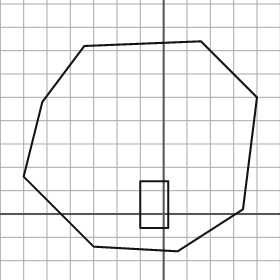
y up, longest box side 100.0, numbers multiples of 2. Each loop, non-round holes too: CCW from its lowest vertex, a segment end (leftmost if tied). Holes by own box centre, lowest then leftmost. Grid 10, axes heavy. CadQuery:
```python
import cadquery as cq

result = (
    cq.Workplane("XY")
    .moveTo(6.0, -16.0)
    .lineTo(34.0, 2.0)
    .lineTo(40.0, 50.0)
    .lineTo(16.0, 74.0)
    .lineTo(-34.0, 72.0)
    .lineTo(-52.0, 48.0)
    .lineTo(-60.0, 16.0)
    .lineTo(-30.0, -14.0)
    .close()
    .moveTo(-10.0, -6.0)
    .lineTo(2.0, -6.0)
    .lineTo(2.0, 14.0)
    .lineTo(-10.0, 14.0)
    .close()
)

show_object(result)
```